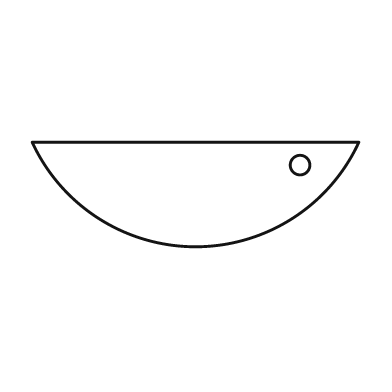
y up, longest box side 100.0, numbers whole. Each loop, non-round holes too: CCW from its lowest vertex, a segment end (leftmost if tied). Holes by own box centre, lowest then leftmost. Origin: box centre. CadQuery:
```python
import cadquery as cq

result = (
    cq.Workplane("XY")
    .moveTo(-50.0, 16.0)
    .threePointArc((0.0, -16.0), (50.0, 16.0))
    .close()
    .moveTo(32.0, 9.0)
    .circle(3.0)
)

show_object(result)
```